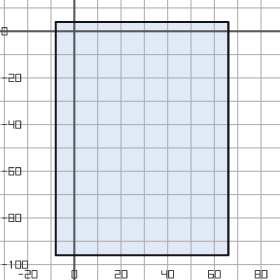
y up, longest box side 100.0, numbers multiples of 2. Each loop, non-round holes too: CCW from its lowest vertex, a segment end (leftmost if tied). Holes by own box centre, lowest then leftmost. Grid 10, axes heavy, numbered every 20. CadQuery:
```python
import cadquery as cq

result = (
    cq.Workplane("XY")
    .moveTo(-8.0, -96.0)
    .lineTo(66.0, -96.0)
    .lineTo(66.0, 4.0)
    .lineTo(-8.0, 4.0)
    .close()
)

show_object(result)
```